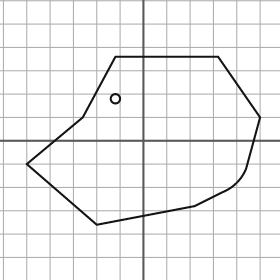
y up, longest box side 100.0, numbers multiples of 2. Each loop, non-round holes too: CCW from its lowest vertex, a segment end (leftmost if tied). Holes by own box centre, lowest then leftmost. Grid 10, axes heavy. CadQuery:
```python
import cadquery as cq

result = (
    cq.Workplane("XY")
    .moveTo(-20.0, -36.0)
    .lineTo(22.0, -28.0)
    .lineTo(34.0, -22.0)
    .threePointArc((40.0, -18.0), (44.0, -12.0))
    .lineTo(50.0, 10.0)
    .lineTo(32.0, 36.0)
    .lineTo(-12.0, 36.0)
    .lineTo(-26.0, 10.0)
    .lineTo(-50.0, -10.0)
    .close()
    .moveTo(-12.0, 18.0)
    .circle(2.0)
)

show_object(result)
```